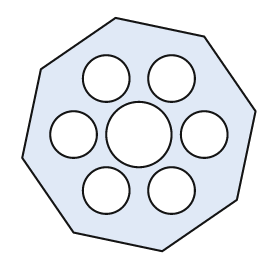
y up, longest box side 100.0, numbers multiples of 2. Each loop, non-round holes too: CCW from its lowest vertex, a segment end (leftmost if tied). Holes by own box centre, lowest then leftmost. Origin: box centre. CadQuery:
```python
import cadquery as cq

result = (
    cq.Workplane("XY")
    .moveTo(10.0, -50.0)
    .lineTo(42.0, -28.0)
    .lineTo(50.0, 10.0)
    .lineTo(28.0, 42.0)
    .lineTo(-10.0, 50.0)
    .lineTo(-42.0, 28.0)
    .lineTo(-50.0, -10.0)
    .lineTo(-28.0, -42.0)
    .close()
    .moveTo(-14.0, -24.0)
    .circle(10.0)
    .moveTo(14.0, -24.0)
    .circle(10.0)
    .moveTo(-28.0, 0.0)
    .circle(10.0)
    .moveTo(0.0, 0.0)
    .circle(14.0)
    .moveTo(28.0, 0.0)
    .circle(10.0)
    .moveTo(-14.0, 24.0)
    .circle(10.0)
    .moveTo(14.0, 24.0)
    .circle(10.0)
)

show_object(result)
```